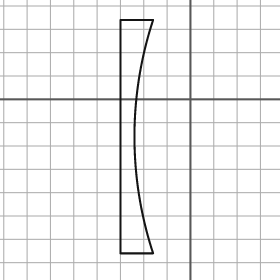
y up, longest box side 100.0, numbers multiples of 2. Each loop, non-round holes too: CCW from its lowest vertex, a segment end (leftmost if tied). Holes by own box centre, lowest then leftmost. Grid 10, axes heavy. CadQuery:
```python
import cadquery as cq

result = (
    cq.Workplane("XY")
    .moveTo(-30.0, -66.0)
    .lineTo(-16.0, -66.0)
    .threePointArc((-24.0, -16.0), (-16.0, 34.0))
    .lineTo(-30.0, 34.0)
    .close()
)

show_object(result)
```